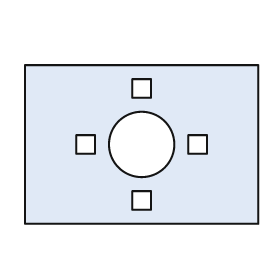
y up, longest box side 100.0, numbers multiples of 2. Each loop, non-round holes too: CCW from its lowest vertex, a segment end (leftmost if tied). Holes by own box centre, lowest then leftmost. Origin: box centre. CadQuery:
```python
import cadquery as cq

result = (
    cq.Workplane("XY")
    .moveTo(-50.0, -34.0)
    .lineTo(50.0, -34.0)
    .lineTo(50.0, 34.0)
    .lineTo(-50.0, 34.0)
    .close()
    .moveTo(-4.0, -28.0)
    .lineTo(4.0, -28.0)
    .lineTo(4.0, -20.0)
    .lineTo(-4.0, -20.0)
    .close()
    .moveTo(-28.0, -4.0)
    .lineTo(-20.0, -4.0)
    .lineTo(-20.0, 4.0)
    .lineTo(-28.0, 4.0)
    .close()
    .moveTo(0.0, 0.0)
    .circle(14.0)
    .moveTo(20.0, -4.0)
    .lineTo(28.0, -4.0)
    .lineTo(28.0, 4.0)
    .lineTo(20.0, 4.0)
    .close()
    .moveTo(-4.0, 20.0)
    .lineTo(4.0, 20.0)
    .lineTo(4.0, 28.0)
    .lineTo(-4.0, 28.0)
    .close()
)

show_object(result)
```